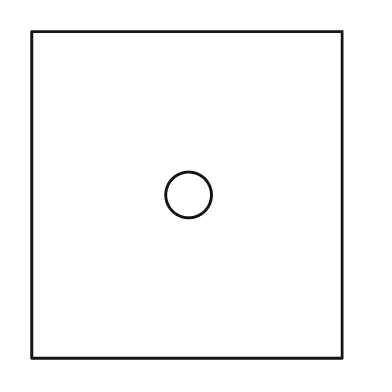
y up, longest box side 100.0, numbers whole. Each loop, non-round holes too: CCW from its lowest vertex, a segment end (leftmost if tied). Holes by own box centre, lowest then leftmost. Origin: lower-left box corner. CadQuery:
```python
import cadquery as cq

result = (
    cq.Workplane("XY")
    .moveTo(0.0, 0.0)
    .lineTo(95.0, 0.0)
    .lineTo(95.0, 100.0)
    .lineTo(0.0, 100.0)
    .close()
    .moveTo(48.0, 50.0)
    .circle(7.0)
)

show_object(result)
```